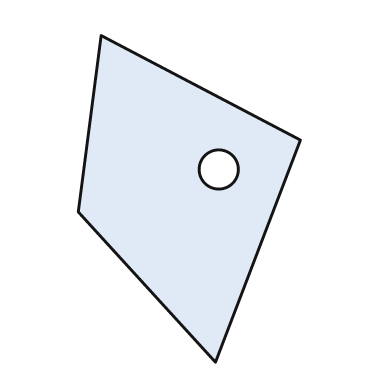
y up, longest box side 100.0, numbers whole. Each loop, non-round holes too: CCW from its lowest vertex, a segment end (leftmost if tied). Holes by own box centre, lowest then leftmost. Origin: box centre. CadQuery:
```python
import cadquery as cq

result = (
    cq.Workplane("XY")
    .moveTo(8.0, -50.0)
    .lineTo(34.0, 18.0)
    .lineTo(-27.0, 50.0)
    .lineTo(-34.0, -4.0)
    .close()
    .moveTo(9.0, 9.0)
    .circle(6.0)
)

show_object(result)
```